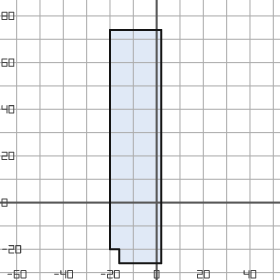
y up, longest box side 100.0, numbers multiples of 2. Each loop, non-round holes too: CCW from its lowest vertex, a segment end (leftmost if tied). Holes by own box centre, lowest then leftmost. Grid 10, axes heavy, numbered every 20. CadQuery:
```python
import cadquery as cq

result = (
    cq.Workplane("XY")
    .moveTo(-16.0, -26.0)
    .lineTo(2.0, -26.0)
    .lineTo(2.0, 74.0)
    .lineTo(-20.0, 74.0)
    .lineTo(-20.0, -20.0)
    .lineTo(-16.0, -20.0)
    .close()
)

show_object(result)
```